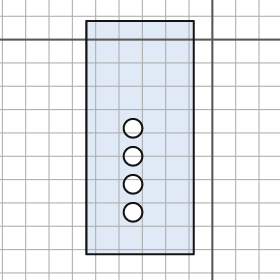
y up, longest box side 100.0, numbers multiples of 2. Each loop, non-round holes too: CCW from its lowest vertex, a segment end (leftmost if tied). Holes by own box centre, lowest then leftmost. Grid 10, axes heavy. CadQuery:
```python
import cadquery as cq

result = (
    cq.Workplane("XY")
    .moveTo(-54.0, -92.0)
    .lineTo(-8.0, -92.0)
    .lineTo(-8.0, 8.0)
    .lineTo(-54.0, 8.0)
    .close()
    .moveTo(-34.0, -74.0)
    .circle(4.0)
    .moveTo(-34.0, -62.0)
    .circle(4.0)
    .moveTo(-34.0, -50.0)
    .circle(4.0)
    .moveTo(-34.0, -38.0)
    .circle(4.0)
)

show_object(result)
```